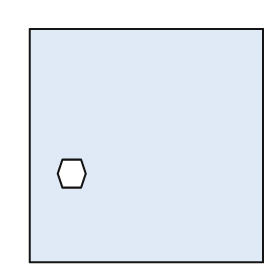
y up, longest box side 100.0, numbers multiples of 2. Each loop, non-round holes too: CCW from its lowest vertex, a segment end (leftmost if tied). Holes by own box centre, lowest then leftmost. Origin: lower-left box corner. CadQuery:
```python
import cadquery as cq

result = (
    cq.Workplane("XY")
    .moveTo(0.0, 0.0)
    .lineTo(100.0, 0.0)
    .lineTo(100.0, 100.0)
    .lineTo(0.0, 100.0)
    .close()
    .moveTo(14.0, 32.0)
    .lineTo(22.0, 32.0)
    .lineTo(24.0, 38.0)
    .lineTo(22.0, 44.0)
    .lineTo(14.0, 44.0)
    .lineTo(12.0, 38.0)
    .close()
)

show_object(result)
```